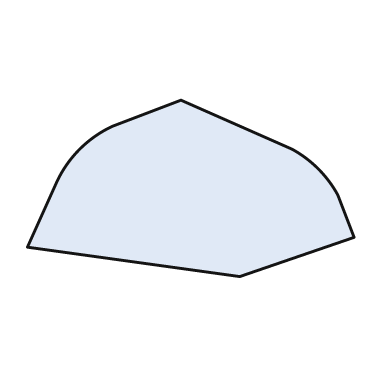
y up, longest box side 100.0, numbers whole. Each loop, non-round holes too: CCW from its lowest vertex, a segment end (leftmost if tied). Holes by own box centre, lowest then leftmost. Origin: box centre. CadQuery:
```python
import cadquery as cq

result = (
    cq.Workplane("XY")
    .moveTo(15.0, -27.0)
    .lineTo(50.0, -15.0)
    .lineTo(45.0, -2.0)
    .threePointArc((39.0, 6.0), (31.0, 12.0))
    .lineTo(-3.0, 27.0)
    .lineTo(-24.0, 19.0)
    .threePointArc((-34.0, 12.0), (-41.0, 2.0))
    .lineTo(-50.0, -18.0)
    .close()
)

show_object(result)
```